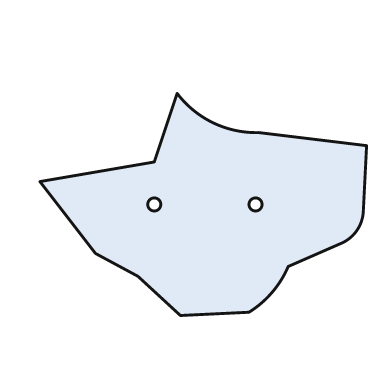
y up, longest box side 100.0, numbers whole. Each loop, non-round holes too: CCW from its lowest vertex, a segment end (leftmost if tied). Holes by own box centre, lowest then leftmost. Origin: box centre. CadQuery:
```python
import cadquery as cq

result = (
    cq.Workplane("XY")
    .moveTo(-7.0, -34.0)
    .lineTo(14.0, -33.0)
    .threePointArc((21.0, -27.0), (26.0, -19.0))
    .lineTo(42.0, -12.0)
    .threePointArc((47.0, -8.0), (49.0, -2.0))
    .lineTo(50.0, 18.0)
    .lineTo(17.0, 22.0)
    .threePointArc((3.0, 25.0), (-8.0, 34.0))
    .lineTo(-15.0, 13.0)
    .lineTo(-50.0, 7.0)
    .lineTo(-33.0, -15.0)
    .lineTo(-20.0, -22.0)
    .close()
    .moveTo(-15.0, 0.0)
    .circle(2.0)
    .moveTo(16.0, 0.0)
    .circle(2.0)
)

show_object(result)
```